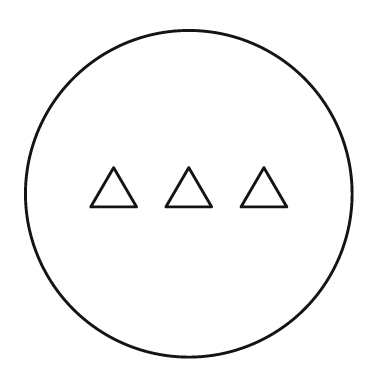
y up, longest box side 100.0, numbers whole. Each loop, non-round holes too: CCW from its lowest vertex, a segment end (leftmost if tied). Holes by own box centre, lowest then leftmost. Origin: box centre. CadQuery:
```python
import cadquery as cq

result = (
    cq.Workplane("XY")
    .moveTo(0.0, 0.0)
    .circle(50.0)
    .moveTo(-30.0, -4.0)
    .lineTo(-16.0, -4.0)
    .lineTo(-23.0, 8.0)
    .close()
    .moveTo(-7.0, -4.0)
    .lineTo(7.0, -4.0)
    .lineTo(0.0, 8.0)
    .close()
    .moveTo(16.0, -4.0)
    .lineTo(30.0, -4.0)
    .lineTo(23.0, 8.0)
    .close()
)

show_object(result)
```